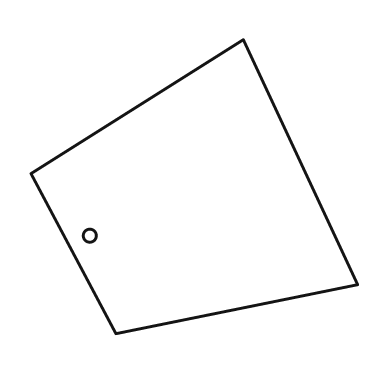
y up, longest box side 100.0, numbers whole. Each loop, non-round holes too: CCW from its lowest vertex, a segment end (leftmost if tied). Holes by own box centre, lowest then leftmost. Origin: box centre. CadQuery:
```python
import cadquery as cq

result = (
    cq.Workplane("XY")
    .moveTo(-24.0, -45.0)
    .lineTo(50.0, -30.0)
    .lineTo(15.0, 45.0)
    .lineTo(-50.0, 4.0)
    .close()
    .moveTo(-32.0, -15.0)
    .circle(2.0)
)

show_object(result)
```